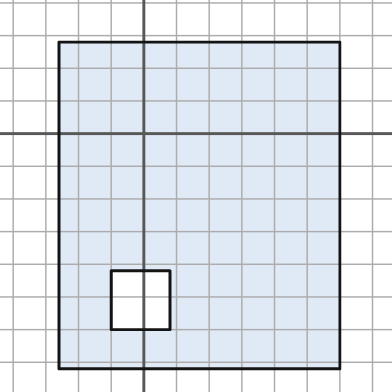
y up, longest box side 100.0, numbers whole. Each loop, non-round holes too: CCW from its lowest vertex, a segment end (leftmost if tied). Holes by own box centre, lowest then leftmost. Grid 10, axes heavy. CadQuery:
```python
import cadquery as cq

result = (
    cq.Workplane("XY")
    .moveTo(-26.0, -72.0)
    .lineTo(60.0, -72.0)
    .lineTo(60.0, 28.0)
    .lineTo(-26.0, 28.0)
    .close()
    .moveTo(-10.0, -60.0)
    .lineTo(8.0, -60.0)
    .lineTo(8.0, -42.0)
    .lineTo(-10.0, -42.0)
    .close()
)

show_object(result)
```